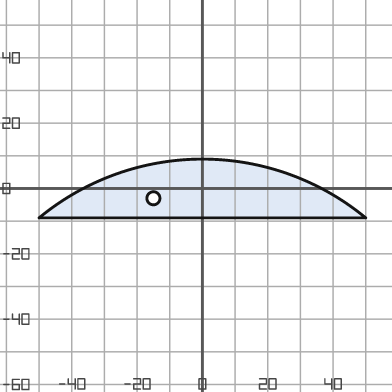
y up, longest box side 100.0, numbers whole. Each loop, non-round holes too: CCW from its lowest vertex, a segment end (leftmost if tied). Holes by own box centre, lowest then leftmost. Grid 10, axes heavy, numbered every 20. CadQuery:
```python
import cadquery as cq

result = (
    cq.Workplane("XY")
    .moveTo(-50.0, -9.0)
    .lineTo(50.0, -9.0)
    .threePointArc((0.0, 9.0), (-50.0, -9.0))
    .close()
    .moveTo(-15.0, -3.0)
    .circle(2.0)
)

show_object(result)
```